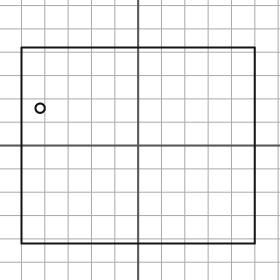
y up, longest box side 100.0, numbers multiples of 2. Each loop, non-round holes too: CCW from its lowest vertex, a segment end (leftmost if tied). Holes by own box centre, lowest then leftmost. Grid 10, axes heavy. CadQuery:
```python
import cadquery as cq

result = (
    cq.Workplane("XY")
    .moveTo(-50.0, -42.0)
    .lineTo(50.0, -42.0)
    .lineTo(50.0, 42.0)
    .lineTo(-50.0, 42.0)
    .close()
    .moveTo(-42.0, 16.0)
    .circle(2.0)
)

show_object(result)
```